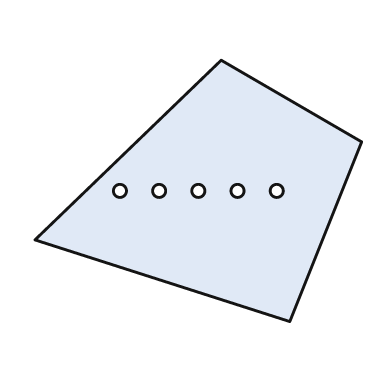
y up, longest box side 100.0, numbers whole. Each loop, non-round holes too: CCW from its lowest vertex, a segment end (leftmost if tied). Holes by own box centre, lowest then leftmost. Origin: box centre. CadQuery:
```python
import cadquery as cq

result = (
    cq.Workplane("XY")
    .moveTo(28.0, -40.0)
    .lineTo(50.0, 15.0)
    .lineTo(7.0, 40.0)
    .lineTo(-50.0, -15.0)
    .close()
    .moveTo(-24.0, 0.0)
    .circle(2.0)
    .moveTo(-12.0, 0.0)
    .circle(2.0)
    .moveTo(0.0, 0.0)
    .circle(2.0)
    .moveTo(12.0, 0.0)
    .circle(2.0)
    .moveTo(24.0, 0.0)
    .circle(2.0)
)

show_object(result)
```